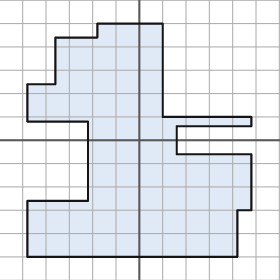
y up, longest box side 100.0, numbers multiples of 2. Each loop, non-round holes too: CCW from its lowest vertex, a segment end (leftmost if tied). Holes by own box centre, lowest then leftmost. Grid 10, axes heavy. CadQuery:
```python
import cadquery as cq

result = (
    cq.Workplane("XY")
    .moveTo(-48.0, -50.0)
    .lineTo(42.0, -50.0)
    .lineTo(42.0, -30.0)
    .lineTo(48.0, -30.0)
    .lineTo(48.0, -6.0)
    .lineTo(16.0, -6.0)
    .lineTo(16.0, 6.0)
    .lineTo(48.0, 6.0)
    .lineTo(48.0, 10.0)
    .lineTo(10.0, 10.0)
    .lineTo(10.0, 50.0)
    .lineTo(-18.0, 50.0)
    .lineTo(-18.0, 44.0)
    .lineTo(-36.0, 44.0)
    .lineTo(-36.0, 24.0)
    .lineTo(-48.0, 24.0)
    .lineTo(-48.0, 8.0)
    .lineTo(-22.0, 8.0)
    .lineTo(-22.0, -26.0)
    .lineTo(-48.0, -26.0)
    .close()
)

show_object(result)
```